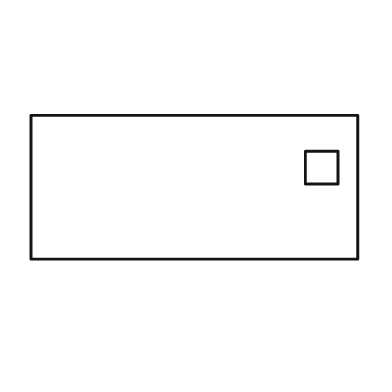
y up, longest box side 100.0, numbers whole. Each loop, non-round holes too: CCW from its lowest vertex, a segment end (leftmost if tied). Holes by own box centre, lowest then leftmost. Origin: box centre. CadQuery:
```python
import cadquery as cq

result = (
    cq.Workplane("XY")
    .moveTo(-50.0, -22.0)
    .lineTo(50.0, -22.0)
    .lineTo(50.0, 22.0)
    .lineTo(-50.0, 22.0)
    .close()
    .moveTo(34.0, 1.0)
    .lineTo(44.0, 1.0)
    .lineTo(44.0, 11.0)
    .lineTo(34.0, 11.0)
    .close()
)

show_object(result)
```